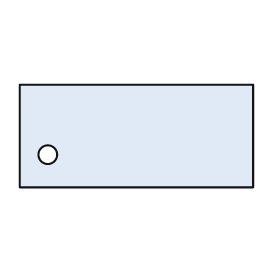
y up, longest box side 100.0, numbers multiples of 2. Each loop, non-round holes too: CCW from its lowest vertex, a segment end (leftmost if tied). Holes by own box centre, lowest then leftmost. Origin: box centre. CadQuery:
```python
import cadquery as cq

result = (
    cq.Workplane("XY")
    .moveTo(-50.0, -22.0)
    .lineTo(50.0, -22.0)
    .lineTo(50.0, 22.0)
    .lineTo(-50.0, 22.0)
    .close()
    .moveTo(-38.0, -8.0)
    .circle(4.0)
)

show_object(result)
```